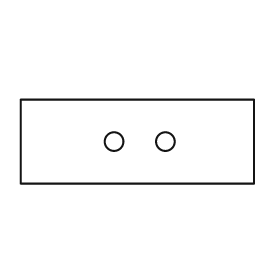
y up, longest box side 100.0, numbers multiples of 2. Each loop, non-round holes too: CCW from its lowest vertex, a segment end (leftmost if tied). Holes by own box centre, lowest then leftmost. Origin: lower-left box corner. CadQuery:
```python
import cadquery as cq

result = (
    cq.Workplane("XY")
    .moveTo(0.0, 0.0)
    .lineTo(100.0, 0.0)
    .lineTo(100.0, 36.0)
    .lineTo(0.0, 36.0)
    .close()
    .moveTo(40.0, 18.0)
    .circle(4.0)
    .moveTo(62.0, 18.0)
    .circle(4.0)
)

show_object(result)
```